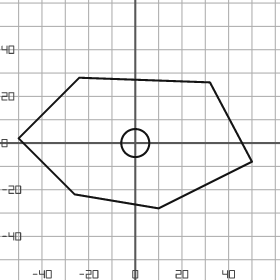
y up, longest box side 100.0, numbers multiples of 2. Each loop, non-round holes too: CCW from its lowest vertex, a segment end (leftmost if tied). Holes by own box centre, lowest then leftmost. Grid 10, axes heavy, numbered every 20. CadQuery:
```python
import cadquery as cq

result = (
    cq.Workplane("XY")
    .moveTo(10.0, -28.0)
    .lineTo(50.0, -8.0)
    .lineTo(32.0, 26.0)
    .lineTo(-24.0, 28.0)
    .lineTo(-50.0, 2.0)
    .lineTo(-26.0, -22.0)
    .close()
    .moveTo(0.0, 0.0)
    .circle(6.0)
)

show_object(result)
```